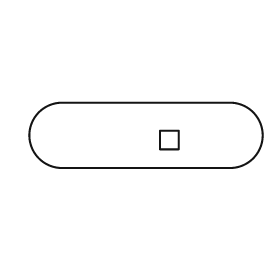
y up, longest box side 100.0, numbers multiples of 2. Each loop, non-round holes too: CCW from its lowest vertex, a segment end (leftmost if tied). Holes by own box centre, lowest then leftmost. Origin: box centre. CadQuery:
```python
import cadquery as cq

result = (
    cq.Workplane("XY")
    .moveTo(-36.0, -14.0)
    .lineTo(36.0, -14.0)
    .threePointArc((50.0, 0.0), (36.0, 14.0))
    .lineTo(-36.0, 14.0)
    .threePointArc((-50.0, 0.0), (-36.0, -14.0))
    .close()
    .moveTo(6.0, -6.0)
    .lineTo(14.0, -6.0)
    .lineTo(14.0, 2.0)
    .lineTo(6.0, 2.0)
    .close()
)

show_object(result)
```